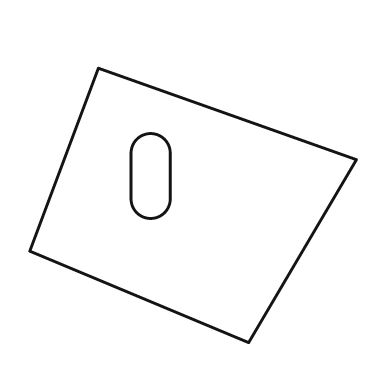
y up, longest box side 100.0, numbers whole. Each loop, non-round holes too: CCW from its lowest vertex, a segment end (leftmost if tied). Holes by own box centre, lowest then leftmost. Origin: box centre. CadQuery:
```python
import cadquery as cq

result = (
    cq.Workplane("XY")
    .moveTo(17.0, -42.0)
    .lineTo(50.0, 14.0)
    .lineTo(-29.0, 42.0)
    .lineTo(-50.0, -14.0)
    .close()
    .moveTo(-19.0, 2.0)
    .threePointArc((-13.0, -4.0), (-7.0, 2.0))
    .lineTo(-7.0, 16.0)
    .threePointArc((-13.0, 22.0), (-19.0, 16.0))
    .close()
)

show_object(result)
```